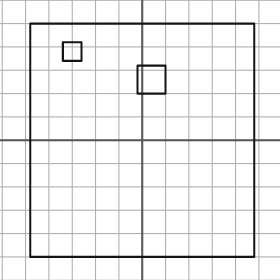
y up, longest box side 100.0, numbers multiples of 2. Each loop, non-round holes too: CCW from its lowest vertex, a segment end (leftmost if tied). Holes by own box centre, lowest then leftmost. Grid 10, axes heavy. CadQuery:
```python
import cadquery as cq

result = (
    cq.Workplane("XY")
    .moveTo(-48.0, -50.0)
    .lineTo(48.0, -50.0)
    .lineTo(48.0, 50.0)
    .lineTo(-48.0, 50.0)
    .close()
    .moveTo(-2.0, 20.0)
    .lineTo(10.0, 20.0)
    .lineTo(10.0, 32.0)
    .lineTo(-2.0, 32.0)
    .close()
    .moveTo(-34.0, 34.0)
    .lineTo(-26.0, 34.0)
    .lineTo(-26.0, 42.0)
    .lineTo(-34.0, 42.0)
    .close()
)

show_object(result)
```